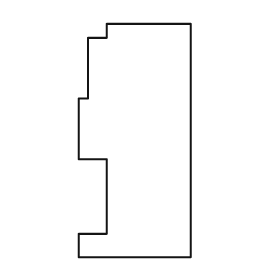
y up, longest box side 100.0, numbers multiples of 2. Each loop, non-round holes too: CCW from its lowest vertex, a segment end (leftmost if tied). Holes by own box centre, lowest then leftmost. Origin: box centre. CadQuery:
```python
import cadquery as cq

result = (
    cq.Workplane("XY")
    .moveTo(-24.0, -50.0)
    .lineTo(24.0, -50.0)
    .lineTo(24.0, 50.0)
    .lineTo(-12.0, 50.0)
    .lineTo(-12.0, 44.0)
    .lineTo(-20.0, 44.0)
    .lineTo(-20.0, 18.0)
    .lineTo(-24.0, 18.0)
    .lineTo(-24.0, -8.0)
    .lineTo(-12.0, -8.0)
    .lineTo(-12.0, -40.0)
    .lineTo(-24.0, -40.0)
    .close()
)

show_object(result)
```